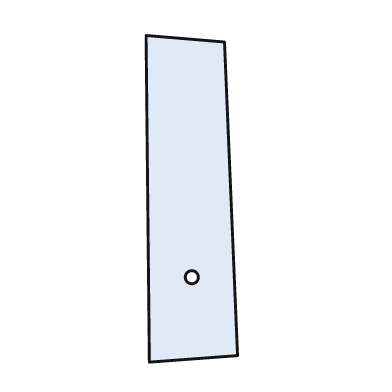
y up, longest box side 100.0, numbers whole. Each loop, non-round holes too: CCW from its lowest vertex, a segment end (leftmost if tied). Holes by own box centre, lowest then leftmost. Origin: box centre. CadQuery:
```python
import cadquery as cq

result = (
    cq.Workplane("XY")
    .moveTo(-13.0, -50.0)
    .lineTo(14.0, -48.0)
    .lineTo(10.0, 48.0)
    .lineTo(-14.0, 50.0)
    .close()
    .moveTo(0.0, -24.0)
    .circle(2.0)
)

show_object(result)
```